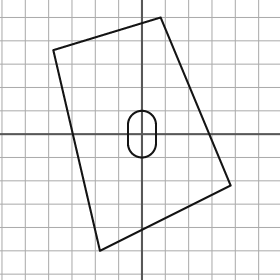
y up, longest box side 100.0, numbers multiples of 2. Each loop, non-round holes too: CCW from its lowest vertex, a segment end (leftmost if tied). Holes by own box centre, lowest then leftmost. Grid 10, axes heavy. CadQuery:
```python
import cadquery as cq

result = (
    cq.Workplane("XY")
    .moveTo(-18.0, -50.0)
    .lineTo(38.0, -22.0)
    .lineTo(8.0, 50.0)
    .lineTo(-38.0, 36.0)
    .close()
    .moveTo(-6.0, -4.0)
    .threePointArc((0.0, -10.0), (6.0, -4.0))
    .lineTo(6.0, 4.0)
    .threePointArc((0.0, 10.0), (-6.0, 4.0))
    .close()
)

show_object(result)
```